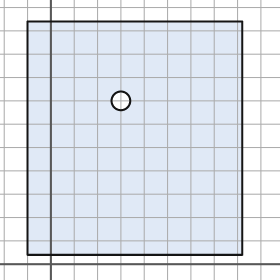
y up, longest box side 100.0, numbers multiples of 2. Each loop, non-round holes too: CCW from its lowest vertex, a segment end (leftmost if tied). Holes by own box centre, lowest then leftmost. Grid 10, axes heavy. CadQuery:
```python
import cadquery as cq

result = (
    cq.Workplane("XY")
    .moveTo(-10.0, 4.0)
    .lineTo(82.0, 4.0)
    .lineTo(82.0, 104.0)
    .lineTo(-10.0, 104.0)
    .close()
    .moveTo(30.0, 70.0)
    .circle(4.0)
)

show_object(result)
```